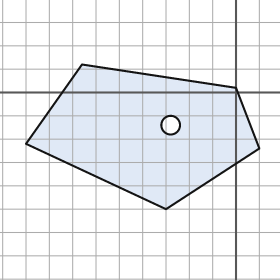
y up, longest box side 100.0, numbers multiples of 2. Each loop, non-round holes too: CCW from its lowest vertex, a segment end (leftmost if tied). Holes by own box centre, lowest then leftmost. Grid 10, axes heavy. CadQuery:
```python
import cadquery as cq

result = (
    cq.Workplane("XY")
    .moveTo(-30.0, -50.0)
    .lineTo(10.0, -24.0)
    .lineTo(0.0, 2.0)
    .lineTo(-66.0, 12.0)
    .lineTo(-90.0, -22.0)
    .close()
    .moveTo(-28.0, -14.0)
    .circle(4.0)
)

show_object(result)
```